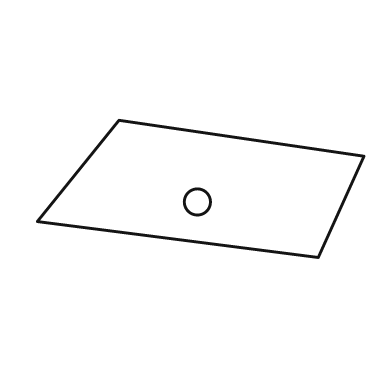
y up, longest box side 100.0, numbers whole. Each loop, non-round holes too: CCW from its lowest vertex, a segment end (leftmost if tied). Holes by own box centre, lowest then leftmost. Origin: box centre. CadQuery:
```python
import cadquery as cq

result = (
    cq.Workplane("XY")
    .moveTo(36.0, -21.0)
    .lineTo(50.0, 10.0)
    .lineTo(-25.0, 21.0)
    .lineTo(-50.0, -10.0)
    .close()
    .moveTo(-1.0, -4.0)
    .circle(4.0)
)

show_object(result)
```